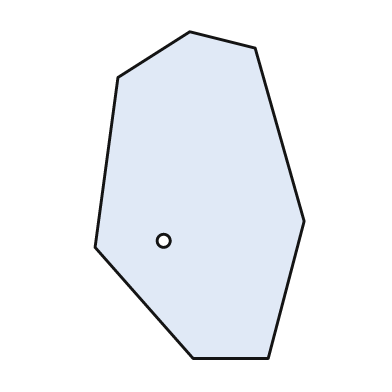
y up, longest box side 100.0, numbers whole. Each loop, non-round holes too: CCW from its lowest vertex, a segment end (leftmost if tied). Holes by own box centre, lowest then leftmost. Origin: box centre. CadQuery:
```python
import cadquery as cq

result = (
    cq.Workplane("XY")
    .moveTo(-2.0, -50.0)
    .lineTo(21.0, -50.0)
    .lineTo(32.0, -8.0)
    .lineTo(17.0, 45.0)
    .lineTo(-3.0, 50.0)
    .lineTo(-25.0, 36.0)
    .lineTo(-32.0, -16.0)
    .close()
    .moveTo(-11.0, -14.0)
    .circle(2.0)
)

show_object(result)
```